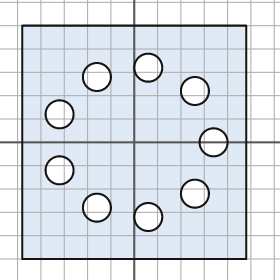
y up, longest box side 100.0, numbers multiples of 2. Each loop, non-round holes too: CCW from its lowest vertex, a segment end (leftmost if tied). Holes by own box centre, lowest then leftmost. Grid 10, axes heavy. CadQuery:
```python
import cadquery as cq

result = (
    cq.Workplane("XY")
    .moveTo(-48.0, -50.0)
    .lineTo(48.0, -50.0)
    .lineTo(48.0, 50.0)
    .lineTo(-48.0, 50.0)
    .close()
    .moveTo(6.0, -32.0)
    .circle(6.0)
    .moveTo(-16.0, -28.0)
    .circle(6.0)
    .moveTo(26.0, -22.0)
    .circle(6.0)
    .moveTo(-32.0, -12.0)
    .circle(6.0)
    .moveTo(34.0, 0.0)
    .circle(6.0)
    .moveTo(-32.0, 12.0)
    .circle(6.0)
    .moveTo(26.0, 22.0)
    .circle(6.0)
    .moveTo(-16.0, 28.0)
    .circle(6.0)
    .moveTo(6.0, 32.0)
    .circle(6.0)
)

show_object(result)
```